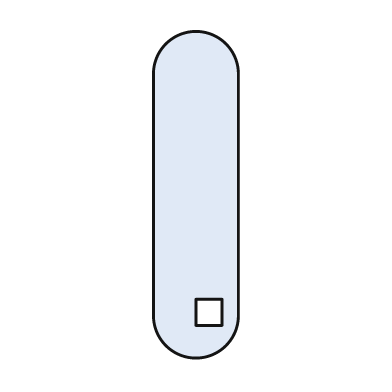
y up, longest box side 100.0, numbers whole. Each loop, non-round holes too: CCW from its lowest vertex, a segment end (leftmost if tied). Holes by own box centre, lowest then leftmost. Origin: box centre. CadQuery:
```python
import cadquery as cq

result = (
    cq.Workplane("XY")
    .moveTo(-13.0, -37.0)
    .threePointArc((0.0, -50.0), (13.0, -37.0))
    .lineTo(13.0, 37.0)
    .threePointArc((0.0, 50.0), (-13.0, 37.0))
    .close()
    .moveTo(0.0, -40.0)
    .lineTo(8.0, -40.0)
    .lineTo(8.0, -32.0)
    .lineTo(0.0, -32.0)
    .close()
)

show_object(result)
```